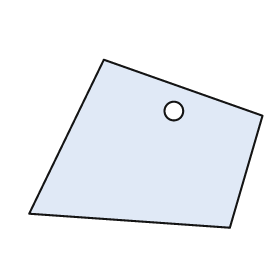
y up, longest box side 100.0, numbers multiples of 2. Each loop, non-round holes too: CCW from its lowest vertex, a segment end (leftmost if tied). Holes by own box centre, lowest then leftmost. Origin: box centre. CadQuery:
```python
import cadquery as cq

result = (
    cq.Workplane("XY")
    .moveTo(36.0, -36.0)
    .lineTo(50.0, 12.0)
    .lineTo(-18.0, 36.0)
    .lineTo(-50.0, -30.0)
    .close()
    .moveTo(12.0, 14.0)
    .circle(4.0)
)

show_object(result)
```